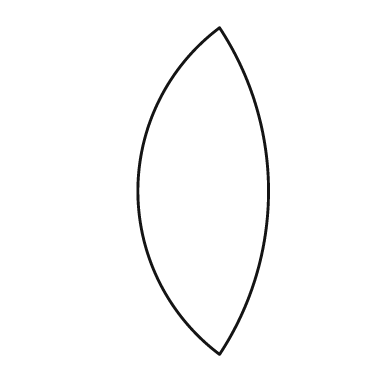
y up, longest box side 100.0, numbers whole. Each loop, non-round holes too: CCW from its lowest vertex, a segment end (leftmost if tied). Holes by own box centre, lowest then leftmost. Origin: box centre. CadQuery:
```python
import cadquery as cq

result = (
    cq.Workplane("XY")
    .moveTo(5.0, -50.0)
    .threePointArc((20.0, 0.0), (5.0, 50.0))
    .threePointArc((-20.0, 0.0), (5.0, -50.0))
    .close()
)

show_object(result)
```